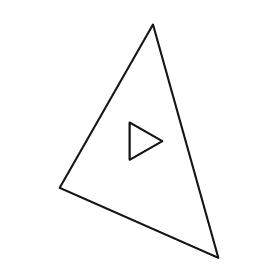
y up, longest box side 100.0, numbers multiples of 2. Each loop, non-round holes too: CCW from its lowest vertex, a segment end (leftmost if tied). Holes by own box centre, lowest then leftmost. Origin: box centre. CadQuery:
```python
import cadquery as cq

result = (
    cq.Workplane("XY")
    .moveTo(34.0, -50.0)
    .lineTo(6.0, 50.0)
    .lineTo(-34.0, -20.0)
    .close()
    .moveTo(-4.0, -8.0)
    .lineTo(10.0, 0.0)
    .lineTo(-4.0, 8.0)
    .close()
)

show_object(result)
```